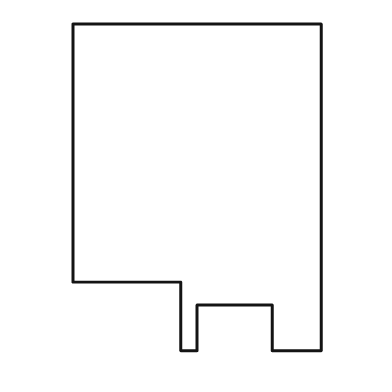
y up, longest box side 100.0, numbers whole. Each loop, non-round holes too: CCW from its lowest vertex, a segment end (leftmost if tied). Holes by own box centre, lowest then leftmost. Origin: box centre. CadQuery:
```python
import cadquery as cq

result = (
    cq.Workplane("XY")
    .moveTo(-5.0, -50.0)
    .lineTo(0.0, -50.0)
    .lineTo(0.0, -36.0)
    .lineTo(23.0, -36.0)
    .lineTo(23.0, -50.0)
    .lineTo(38.0, -50.0)
    .lineTo(38.0, 50.0)
    .lineTo(-38.0, 50.0)
    .lineTo(-38.0, -29.0)
    .lineTo(-5.0, -29.0)
    .close()
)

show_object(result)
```